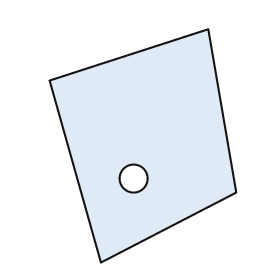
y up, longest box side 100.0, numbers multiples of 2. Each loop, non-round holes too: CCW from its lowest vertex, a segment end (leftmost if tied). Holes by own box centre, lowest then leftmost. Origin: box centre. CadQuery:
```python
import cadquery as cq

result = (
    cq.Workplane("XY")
    .moveTo(-18.0, -50.0)
    .lineTo(40.0, -20.0)
    .lineTo(28.0, 50.0)
    .lineTo(-40.0, 28.0)
    .close()
    .moveTo(-4.0, -14.0)
    .circle(6.0)
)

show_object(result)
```